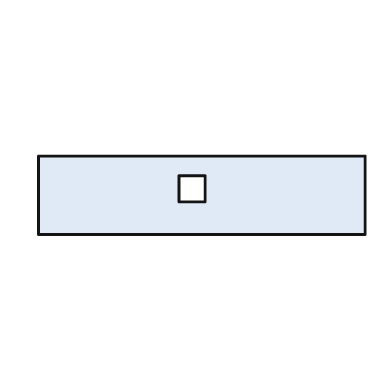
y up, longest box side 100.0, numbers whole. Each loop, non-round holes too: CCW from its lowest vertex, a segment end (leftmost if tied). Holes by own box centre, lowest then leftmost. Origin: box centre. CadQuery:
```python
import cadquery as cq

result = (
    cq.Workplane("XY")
    .moveTo(-50.0, -12.0)
    .lineTo(50.0, -12.0)
    .lineTo(50.0, 12.0)
    .lineTo(-50.0, 12.0)
    .close()
    .moveTo(-7.0, -2.0)
    .lineTo(1.0, -2.0)
    .lineTo(1.0, 6.0)
    .lineTo(-7.0, 6.0)
    .close()
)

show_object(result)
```